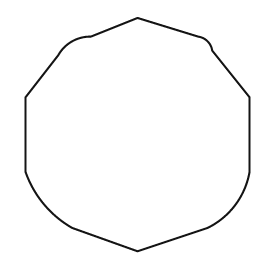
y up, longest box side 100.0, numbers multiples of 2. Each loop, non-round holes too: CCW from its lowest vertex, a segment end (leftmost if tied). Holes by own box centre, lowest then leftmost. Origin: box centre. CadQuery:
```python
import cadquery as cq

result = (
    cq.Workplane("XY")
    .moveTo(0.0, -50.0)
    .lineTo(30.0, -40.0)
    .threePointArc((42.0, -30.0), (48.0, -16.0))
    .lineTo(48.0, 16.0)
    .lineTo(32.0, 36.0)
    .threePointArc((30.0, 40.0), (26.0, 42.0))
    .lineTo(0.0, 50.0)
    .lineTo(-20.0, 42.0)
    .threePointArc((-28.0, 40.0), (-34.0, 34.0))
    .lineTo(-48.0, 16.0)
    .lineTo(-48.0, -16.0)
    .threePointArc((-40.0, -30.0), (-28.0, -40.0))
    .close()
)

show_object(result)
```